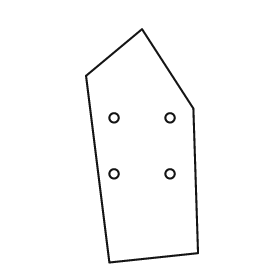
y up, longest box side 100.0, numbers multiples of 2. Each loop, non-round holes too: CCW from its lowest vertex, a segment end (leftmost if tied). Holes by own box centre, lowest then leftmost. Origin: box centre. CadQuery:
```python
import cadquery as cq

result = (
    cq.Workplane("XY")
    .moveTo(-14.0, -50.0)
    .lineTo(24.0, -46.0)
    .lineTo(22.0, 16.0)
    .lineTo(0.0, 50.0)
    .lineTo(-24.0, 30.0)
    .close()
    .moveTo(-12.0, -12.0)
    .circle(2.0)
    .moveTo(12.0, -12.0)
    .circle(2.0)
    .moveTo(-12.0, 12.0)
    .circle(2.0)
    .moveTo(12.0, 12.0)
    .circle(2.0)
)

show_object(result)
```